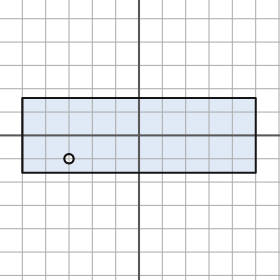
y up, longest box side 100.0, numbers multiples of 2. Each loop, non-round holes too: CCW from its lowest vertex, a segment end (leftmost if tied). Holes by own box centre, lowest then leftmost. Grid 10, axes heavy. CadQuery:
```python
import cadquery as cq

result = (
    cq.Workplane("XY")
    .moveTo(-50.0, -16.0)
    .lineTo(50.0, -16.0)
    .lineTo(50.0, 16.0)
    .lineTo(-50.0, 16.0)
    .close()
    .moveTo(-30.0, -10.0)
    .circle(2.0)
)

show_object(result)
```